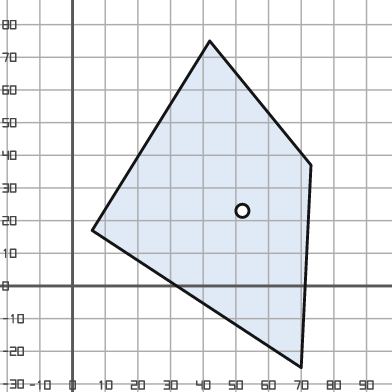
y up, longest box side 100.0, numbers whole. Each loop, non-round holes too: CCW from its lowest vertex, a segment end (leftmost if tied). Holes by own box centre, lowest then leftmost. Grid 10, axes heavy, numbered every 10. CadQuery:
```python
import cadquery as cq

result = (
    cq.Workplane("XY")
    .moveTo(70.0, -25.0)
    .lineTo(73.0, 37.0)
    .lineTo(42.0, 75.0)
    .lineTo(6.0, 17.0)
    .close()
    .moveTo(52.0, 23.0)
    .circle(2.0)
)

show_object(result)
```